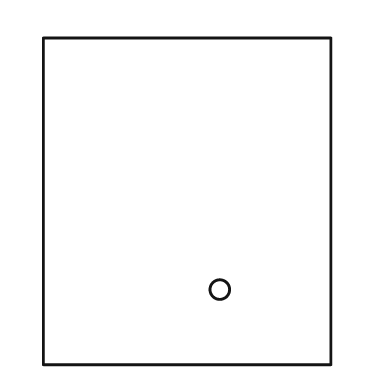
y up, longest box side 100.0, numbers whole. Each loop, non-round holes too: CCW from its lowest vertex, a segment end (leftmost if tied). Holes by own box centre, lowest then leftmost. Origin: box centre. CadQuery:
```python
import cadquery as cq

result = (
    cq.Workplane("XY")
    .moveTo(-44.0, -50.0)
    .lineTo(44.0, -50.0)
    .lineTo(44.0, 50.0)
    .lineTo(-44.0, 50.0)
    .close()
    .moveTo(10.0, -27.0)
    .circle(3.0)
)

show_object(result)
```